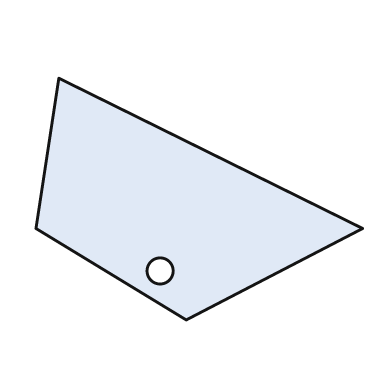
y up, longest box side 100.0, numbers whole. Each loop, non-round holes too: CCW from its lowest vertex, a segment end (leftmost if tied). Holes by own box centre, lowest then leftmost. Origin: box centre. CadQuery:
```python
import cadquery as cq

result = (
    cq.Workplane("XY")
    .moveTo(-4.0, -37.0)
    .lineTo(50.0, -9.0)
    .lineTo(-43.0, 37.0)
    .lineTo(-50.0, -9.0)
    .close()
    .moveTo(-12.0, -22.0)
    .circle(4.0)
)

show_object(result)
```